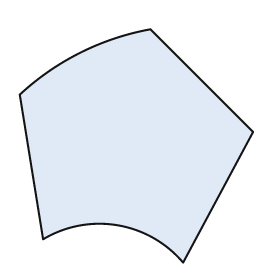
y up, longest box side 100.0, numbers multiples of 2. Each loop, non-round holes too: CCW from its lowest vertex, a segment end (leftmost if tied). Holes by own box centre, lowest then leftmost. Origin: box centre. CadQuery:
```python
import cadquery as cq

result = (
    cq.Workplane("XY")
    .moveTo(20.0, -50.0)
    .lineTo(50.0, 6.0)
    .lineTo(6.0, 50.0)
    .threePointArc((-24.0, 40.0), (-50.0, 22.0))
    .lineTo(-40.0, -40.0)
    .threePointArc((-8.0, -34.0), (20.0, -50.0))
    .close()
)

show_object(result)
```